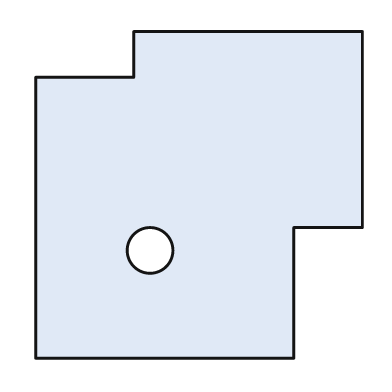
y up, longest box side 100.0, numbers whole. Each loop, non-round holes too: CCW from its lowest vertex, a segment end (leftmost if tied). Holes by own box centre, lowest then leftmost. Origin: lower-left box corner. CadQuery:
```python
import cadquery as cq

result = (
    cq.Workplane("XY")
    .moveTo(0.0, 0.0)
    .lineTo(79.0, 0.0)
    .lineTo(79.0, 40.0)
    .lineTo(100.0, 40.0)
    .lineTo(100.0, 100.0)
    .lineTo(30.0, 100.0)
    .lineTo(30.0, 86.0)
    .lineTo(0.0, 86.0)
    .close()
    .moveTo(35.0, 33.0)
    .circle(7.0)
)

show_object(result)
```